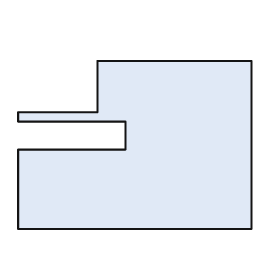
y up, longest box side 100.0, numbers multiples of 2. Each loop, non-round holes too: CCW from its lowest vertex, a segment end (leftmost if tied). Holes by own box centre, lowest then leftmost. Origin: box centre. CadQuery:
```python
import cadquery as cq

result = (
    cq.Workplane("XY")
    .moveTo(-50.0, -36.0)
    .lineTo(50.0, -36.0)
    .lineTo(50.0, 36.0)
    .lineTo(-16.0, 36.0)
    .lineTo(-16.0, 14.0)
    .lineTo(-50.0, 14.0)
    .lineTo(-50.0, 10.0)
    .lineTo(-4.0, 10.0)
    .lineTo(-4.0, -2.0)
    .lineTo(-50.0, -2.0)
    .close()
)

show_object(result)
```